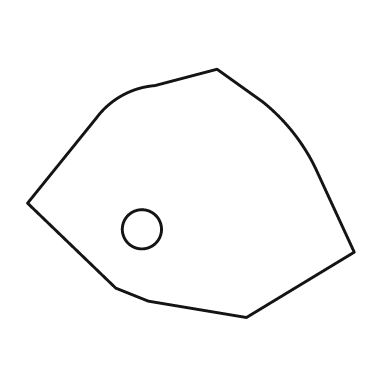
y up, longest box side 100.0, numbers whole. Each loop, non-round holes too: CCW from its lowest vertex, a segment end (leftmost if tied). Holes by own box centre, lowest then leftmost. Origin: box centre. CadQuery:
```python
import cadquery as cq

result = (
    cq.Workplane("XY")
    .moveTo(17.0, -38.0)
    .lineTo(50.0, -18.0)
    .lineTo(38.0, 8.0)
    .threePointArc((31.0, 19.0), (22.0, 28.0))
    .lineTo(8.0, 38.0)
    .lineTo(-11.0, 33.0)
    .threePointArc((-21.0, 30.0), (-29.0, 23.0))
    .lineTo(-50.0, -3.0)
    .lineTo(-23.0, -29.0)
    .lineTo(-13.0, -33.0)
    .close()
    .moveTo(-15.0, -11.0)
    .circle(6.0)
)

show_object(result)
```